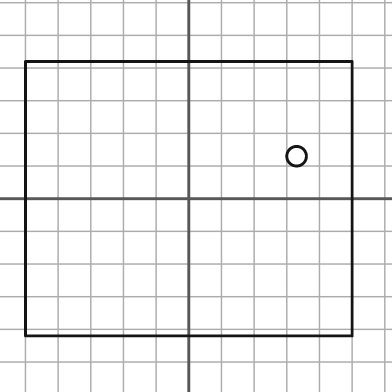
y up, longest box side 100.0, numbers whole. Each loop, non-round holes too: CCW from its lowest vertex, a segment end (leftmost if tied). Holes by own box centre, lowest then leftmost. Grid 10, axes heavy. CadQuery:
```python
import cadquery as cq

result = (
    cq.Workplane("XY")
    .moveTo(-50.0, -42.0)
    .lineTo(50.0, -42.0)
    .lineTo(50.0, 42.0)
    .lineTo(-50.0, 42.0)
    .close()
    .moveTo(33.0, 13.0)
    .circle(3.0)
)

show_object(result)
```